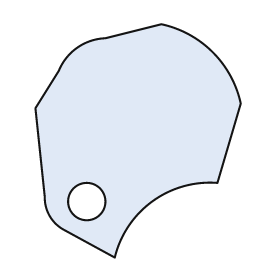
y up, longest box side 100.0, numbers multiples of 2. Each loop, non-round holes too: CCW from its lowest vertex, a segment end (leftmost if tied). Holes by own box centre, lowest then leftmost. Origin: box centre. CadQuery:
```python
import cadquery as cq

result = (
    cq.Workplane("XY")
    .moveTo(-10.0, -50.0)
    .threePointArc((6.0, -26.0), (34.0, -18.0))
    .lineTo(44.0, 16.0)
    .threePointArc((32.0, 38.0), (10.0, 50.0))
    .lineTo(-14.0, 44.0)
    .threePointArc((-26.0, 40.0), (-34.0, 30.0))
    .lineTo(-44.0, 14.0)
    .lineTo(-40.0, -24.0)
    .threePointArc((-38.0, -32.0), (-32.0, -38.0))
    .close()
    .moveTo(-22.0, -26.0)
    .circle(8.0)
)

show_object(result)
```